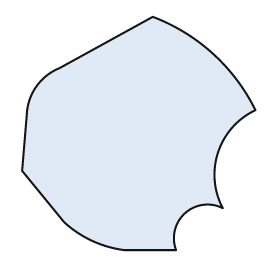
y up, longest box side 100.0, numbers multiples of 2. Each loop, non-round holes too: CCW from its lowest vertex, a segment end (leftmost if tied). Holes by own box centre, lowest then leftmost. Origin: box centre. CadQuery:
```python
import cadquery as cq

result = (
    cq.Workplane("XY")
    .moveTo(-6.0, -50.0)
    .lineTo(16.0, -50.0)
    .threePointArc((20.0, -34.0), (36.0, -32.0))
    .threePointArc((34.0, -8.0), (50.0, 10.0))
    .threePointArc((32.0, 34.0), (6.0, 50.0))
    .lineTo(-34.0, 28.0)
    .threePointArc((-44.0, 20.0), (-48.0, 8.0))
    .lineTo(-50.0, -16.0)
    .lineTo(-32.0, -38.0)
    .threePointArc((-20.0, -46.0), (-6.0, -50.0))
    .close()
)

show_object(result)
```